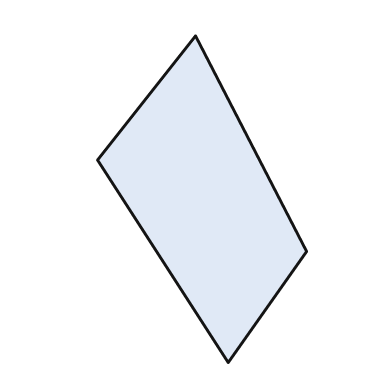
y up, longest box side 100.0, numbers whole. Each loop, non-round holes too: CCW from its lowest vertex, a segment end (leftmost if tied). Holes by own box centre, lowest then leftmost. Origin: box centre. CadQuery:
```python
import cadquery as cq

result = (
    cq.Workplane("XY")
    .moveTo(8.0, -50.0)
    .lineTo(32.0, -16.0)
    .lineTo(-2.0, 50.0)
    .lineTo(-32.0, 12.0)
    .close()
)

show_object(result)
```